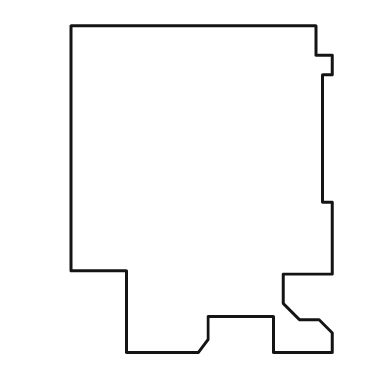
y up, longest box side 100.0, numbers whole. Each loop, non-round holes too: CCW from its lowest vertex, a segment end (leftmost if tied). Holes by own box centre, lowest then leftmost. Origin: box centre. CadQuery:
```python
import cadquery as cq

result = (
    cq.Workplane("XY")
    .moveTo(-23.0, -50.0)
    .lineTo(-1.0, -50.0)
    .lineTo(2.0, -46.0)
    .lineTo(2.0, -39.0)
    .lineTo(22.0, -39.0)
    .lineTo(22.0, -50.0)
    .lineTo(40.0, -50.0)
    .lineTo(40.0, -44.0)
    .lineTo(36.0, -40.0)
    .lineTo(30.0, -40.0)
    .lineTo(25.0, -35.0)
    .lineTo(25.0, -26.0)
    .lineTo(40.0, -26.0)
    .lineTo(40.0, -4.0)
    .lineTo(37.0, -4.0)
    .lineTo(37.0, 35.0)
    .lineTo(40.0, 35.0)
    .lineTo(40.0, 41.0)
    .lineTo(35.0, 41.0)
    .lineTo(35.0, 50.0)
    .lineTo(-40.0, 50.0)
    .lineTo(-40.0, -25.0)
    .lineTo(-23.0, -25.0)
    .close()
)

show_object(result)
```